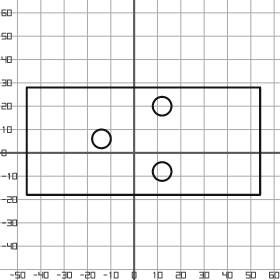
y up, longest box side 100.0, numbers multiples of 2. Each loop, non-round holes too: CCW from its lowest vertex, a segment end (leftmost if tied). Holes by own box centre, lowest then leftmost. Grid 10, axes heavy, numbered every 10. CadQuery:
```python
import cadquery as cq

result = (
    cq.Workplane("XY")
    .moveTo(-46.0, -18.0)
    .lineTo(54.0, -18.0)
    .lineTo(54.0, 28.0)
    .lineTo(-46.0, 28.0)
    .close()
    .moveTo(12.0, -8.0)
    .circle(4.0)
    .moveTo(-14.0, 6.0)
    .circle(4.0)
    .moveTo(12.0, 20.0)
    .circle(4.0)
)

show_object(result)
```